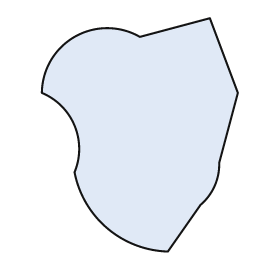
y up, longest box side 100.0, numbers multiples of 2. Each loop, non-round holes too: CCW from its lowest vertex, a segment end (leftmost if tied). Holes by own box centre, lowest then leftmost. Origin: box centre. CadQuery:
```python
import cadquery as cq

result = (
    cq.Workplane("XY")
    .moveTo(12.0, -50.0)
    .lineTo(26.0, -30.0)
    .threePointArc((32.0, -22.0), (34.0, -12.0))
    .lineTo(42.0, 18.0)
    .lineTo(30.0, 50.0)
    .lineTo(0.0, 42.0)
    .threePointArc((-28.0, 42.0), (-42.0, 18.0))
    .threePointArc((-28.0, 4.0), (-28.0, -16.0))
    .threePointArc((-14.0, -40.0), (12.0, -50.0))
    .close()
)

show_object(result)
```